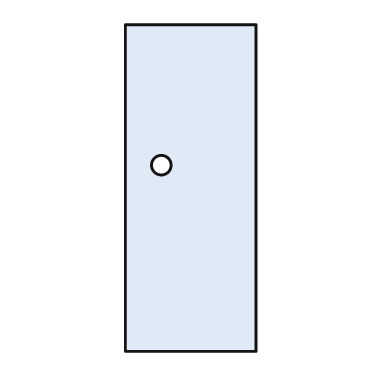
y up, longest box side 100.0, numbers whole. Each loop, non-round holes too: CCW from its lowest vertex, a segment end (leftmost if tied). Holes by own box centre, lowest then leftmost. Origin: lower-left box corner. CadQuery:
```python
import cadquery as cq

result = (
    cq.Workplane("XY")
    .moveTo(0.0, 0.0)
    .lineTo(40.0, 0.0)
    .lineTo(40.0, 100.0)
    .lineTo(0.0, 100.0)
    .close()
    .moveTo(11.0, 57.0)
    .circle(3.0)
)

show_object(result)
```